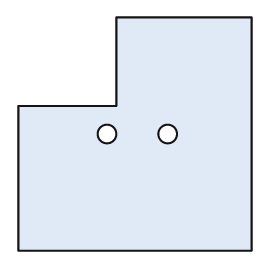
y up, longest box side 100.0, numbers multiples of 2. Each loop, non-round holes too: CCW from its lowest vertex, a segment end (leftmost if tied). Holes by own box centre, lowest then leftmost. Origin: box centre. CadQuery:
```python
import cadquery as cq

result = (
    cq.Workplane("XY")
    .moveTo(-50.0, -50.0)
    .lineTo(50.0, -50.0)
    .lineTo(50.0, 50.0)
    .lineTo(-8.0, 50.0)
    .lineTo(-8.0, 12.0)
    .lineTo(-50.0, 12.0)
    .close()
    .moveTo(-12.0, 0.0)
    .circle(4.0)
    .moveTo(14.0, 0.0)
    .circle(4.0)
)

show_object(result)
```